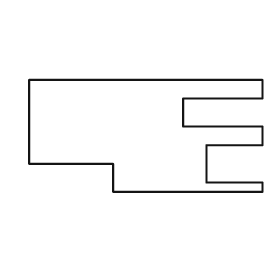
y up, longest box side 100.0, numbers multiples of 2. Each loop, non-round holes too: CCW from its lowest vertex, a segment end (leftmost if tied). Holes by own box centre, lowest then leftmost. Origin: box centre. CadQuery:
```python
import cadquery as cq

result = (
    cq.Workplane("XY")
    .moveTo(-14.0, -24.0)
    .lineTo(50.0, -24.0)
    .lineTo(50.0, -20.0)
    .lineTo(26.0, -20.0)
    .lineTo(26.0, -4.0)
    .lineTo(50.0, -4.0)
    .lineTo(50.0, 4.0)
    .lineTo(16.0, 4.0)
    .lineTo(16.0, 16.0)
    .lineTo(50.0, 16.0)
    .lineTo(50.0, 24.0)
    .lineTo(-50.0, 24.0)
    .lineTo(-50.0, -12.0)
    .lineTo(-14.0, -12.0)
    .close()
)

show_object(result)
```